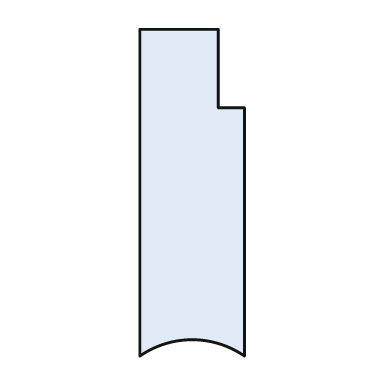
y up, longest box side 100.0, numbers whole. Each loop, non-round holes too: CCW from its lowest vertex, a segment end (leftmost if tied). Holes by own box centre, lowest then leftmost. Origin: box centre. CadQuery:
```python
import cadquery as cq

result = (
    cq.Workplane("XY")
    .moveTo(-16.0, -50.0)
    .threePointArc((0.0, -45.0), (16.0, -50.0))
    .lineTo(16.0, 26.0)
    .lineTo(8.0, 26.0)
    .lineTo(8.0, 50.0)
    .lineTo(-16.0, 50.0)
    .close()
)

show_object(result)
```